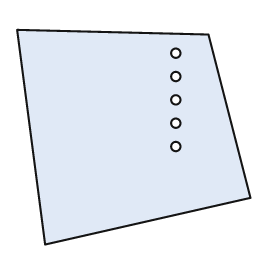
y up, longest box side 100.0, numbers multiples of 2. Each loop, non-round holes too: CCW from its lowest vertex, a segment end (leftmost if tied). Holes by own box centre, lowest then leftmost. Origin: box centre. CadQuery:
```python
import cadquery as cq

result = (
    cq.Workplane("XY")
    .moveTo(-38.0, -46.0)
    .lineTo(50.0, -26.0)
    .lineTo(32.0, 44.0)
    .lineTo(-50.0, 46.0)
    .close()
    .moveTo(18.0, -4.0)
    .circle(2.0)
    .moveTo(18.0, 6.0)
    .circle(2.0)
    .moveTo(18.0, 16.0)
    .circle(2.0)
    .moveTo(18.0, 26.0)
    .circle(2.0)
    .moveTo(18.0, 36.0)
    .circle(2.0)
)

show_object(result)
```